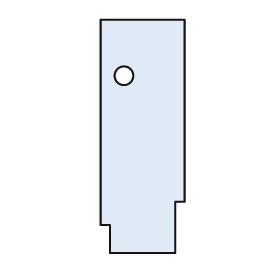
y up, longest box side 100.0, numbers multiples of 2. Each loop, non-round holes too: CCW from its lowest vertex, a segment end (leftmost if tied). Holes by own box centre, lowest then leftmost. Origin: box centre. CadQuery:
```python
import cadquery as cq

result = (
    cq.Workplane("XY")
    .moveTo(-14.0, -50.0)
    .lineTo(14.0, -50.0)
    .lineTo(14.0, -28.0)
    .lineTo(18.0, -28.0)
    .lineTo(18.0, 50.0)
    .lineTo(-18.0, 50.0)
    .lineTo(-18.0, -38.0)
    .lineTo(-14.0, -38.0)
    .close()
    .moveTo(-8.0, 26.0)
    .circle(4.0)
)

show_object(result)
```